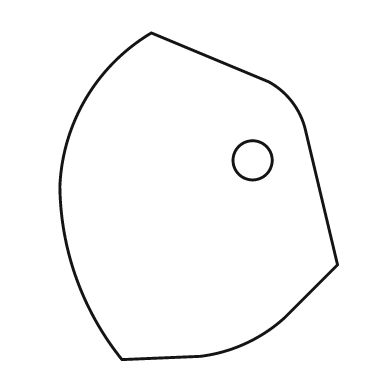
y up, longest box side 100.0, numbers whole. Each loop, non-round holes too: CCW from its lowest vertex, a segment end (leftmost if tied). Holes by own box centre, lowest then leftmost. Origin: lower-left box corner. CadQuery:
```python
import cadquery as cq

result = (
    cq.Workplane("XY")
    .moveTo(19.0, 0.0)
    .lineTo(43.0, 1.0)
    .threePointArc((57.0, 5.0), (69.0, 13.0))
    .lineTo(85.0, 29.0)
    .lineTo(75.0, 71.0)
    .threePointArc((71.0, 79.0), (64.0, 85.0))
    .lineTo(28.0, 100.0)
    .threePointArc((8.0, 80.0), (0.0, 53.0))
    .threePointArc((5.0, 25.0), (19.0, 0.0))
    .close()
    .moveTo(59.0, 61.0)
    .circle(6.0)
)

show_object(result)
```